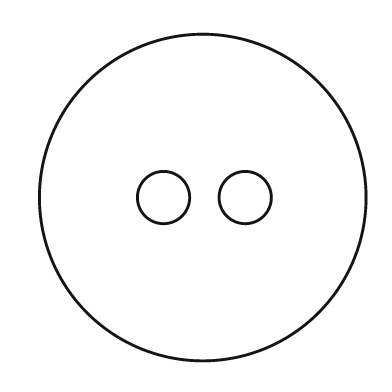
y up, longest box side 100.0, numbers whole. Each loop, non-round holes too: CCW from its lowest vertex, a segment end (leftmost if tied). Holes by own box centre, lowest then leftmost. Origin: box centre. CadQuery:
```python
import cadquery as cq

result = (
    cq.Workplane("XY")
    .moveTo(0.0, 0.0)
    .circle(50.0)
    .moveTo(-12.0, 0.0)
    .circle(8.0)
    .moveTo(13.0, 0.0)
    .circle(8.0)
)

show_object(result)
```